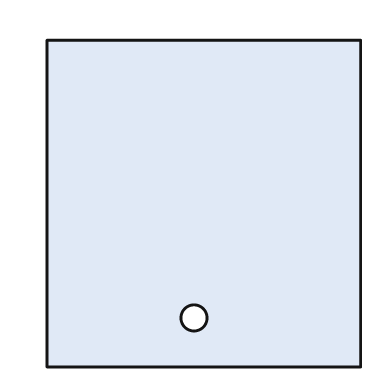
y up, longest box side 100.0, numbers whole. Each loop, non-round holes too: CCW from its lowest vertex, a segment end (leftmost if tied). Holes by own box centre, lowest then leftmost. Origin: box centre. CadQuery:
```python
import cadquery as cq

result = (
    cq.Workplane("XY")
    .moveTo(-48.0, -50.0)
    .lineTo(48.0, -50.0)
    .lineTo(48.0, 50.0)
    .lineTo(-48.0, 50.0)
    .close()
    .moveTo(-3.0, -35.0)
    .circle(4.0)
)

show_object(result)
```